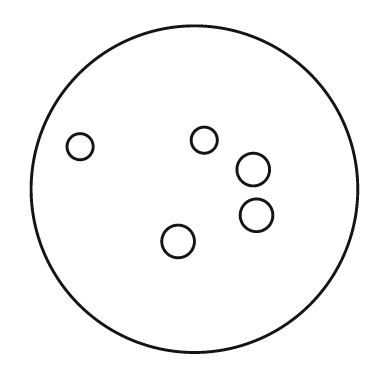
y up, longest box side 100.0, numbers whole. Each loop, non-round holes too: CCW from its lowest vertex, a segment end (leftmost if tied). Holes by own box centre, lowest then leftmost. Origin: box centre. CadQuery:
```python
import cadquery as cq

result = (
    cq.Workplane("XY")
    .moveTo(0.0, 0.0)
    .circle(50.0)
    .moveTo(-5.0, -16.0)
    .circle(5.0)
    .moveTo(19.0, -8.0)
    .circle(5.0)
    .moveTo(18.0, 6.0)
    .circle(5.0)
    .moveTo(-35.0, 13.0)
    .circle(4.0)
    .moveTo(3.0, 15.0)
    .circle(4.0)
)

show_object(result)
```